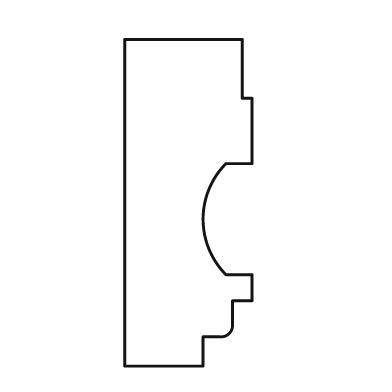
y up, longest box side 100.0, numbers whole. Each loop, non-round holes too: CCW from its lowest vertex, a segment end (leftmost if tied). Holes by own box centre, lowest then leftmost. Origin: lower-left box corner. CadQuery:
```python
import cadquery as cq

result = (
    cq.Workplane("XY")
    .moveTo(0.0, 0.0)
    .lineTo(24.0, 0.0)
    .lineTo(24.0, 9.0)
    .lineTo(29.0, 9.0)
    .threePointArc((32.0, 10.0), (33.0, 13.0))
    .lineTo(33.0, 20.0)
    .lineTo(39.0, 20.0)
    .lineTo(39.0, 28.0)
    .lineTo(31.0, 28.0)
    .threePointArc((24.0, 45.0), (31.0, 62.0))
    .lineTo(39.0, 62.0)
    .lineTo(39.0, 82.0)
    .lineTo(36.0, 82.0)
    .lineTo(36.0, 100.0)
    .lineTo(0.0, 100.0)
    .close()
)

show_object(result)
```